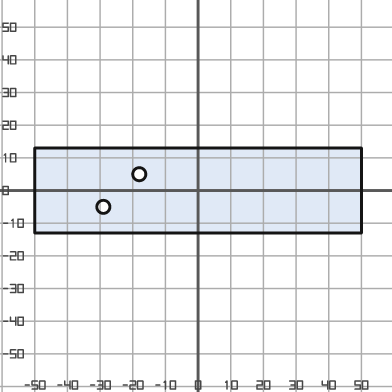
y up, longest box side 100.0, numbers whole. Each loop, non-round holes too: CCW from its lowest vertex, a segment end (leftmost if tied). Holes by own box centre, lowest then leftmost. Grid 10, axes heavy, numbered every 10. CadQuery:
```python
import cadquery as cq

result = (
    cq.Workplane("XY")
    .moveTo(-50.0, -13.0)
    .lineTo(50.0, -13.0)
    .lineTo(50.0, 13.0)
    .lineTo(-50.0, 13.0)
    .close()
    .moveTo(-29.0, -5.0)
    .circle(2.0)
    .moveTo(-18.0, 5.0)
    .circle(2.0)
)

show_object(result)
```